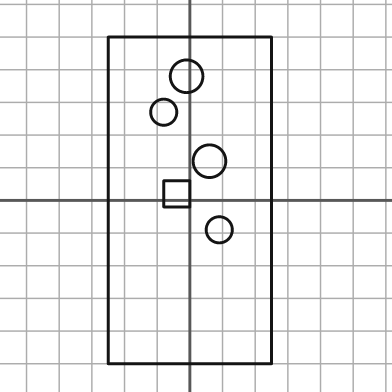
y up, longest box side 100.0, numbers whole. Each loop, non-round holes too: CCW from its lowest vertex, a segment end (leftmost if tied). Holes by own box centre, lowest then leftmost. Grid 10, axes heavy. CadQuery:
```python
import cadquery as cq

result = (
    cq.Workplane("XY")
    .moveTo(-25.0, -50.0)
    .lineTo(25.0, -50.0)
    .lineTo(25.0, 50.0)
    .lineTo(-25.0, 50.0)
    .close()
    .moveTo(9.0, -9.0)
    .circle(4.0)
    .moveTo(-8.0, -2.0)
    .lineTo(0.0, -2.0)
    .lineTo(0.0, 6.0)
    .lineTo(-8.0, 6.0)
    .close()
    .moveTo(6.0, 12.0)
    .circle(5.0)
    .moveTo(-8.0, 27.0)
    .circle(4.0)
    .moveTo(-1.0, 38.0)
    .circle(5.0)
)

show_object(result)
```